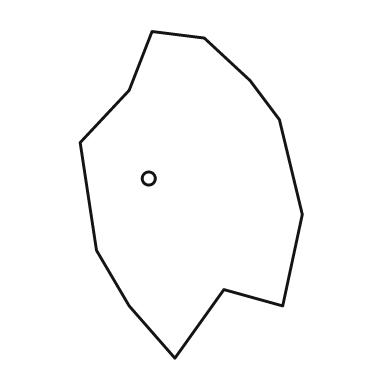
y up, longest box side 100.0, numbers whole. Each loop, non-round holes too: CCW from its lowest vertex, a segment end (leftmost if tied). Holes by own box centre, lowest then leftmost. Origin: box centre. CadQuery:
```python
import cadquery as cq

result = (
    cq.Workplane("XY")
    .moveTo(-5.0, -50.0)
    .lineTo(10.0, -29.0)
    .lineTo(28.0, -34.0)
    .lineTo(34.0, -6.0)
    .lineTo(27.0, 23.0)
    .lineTo(18.0, 35.0)
    .lineTo(4.0, 48.0)
    .lineTo(-12.0, 50.0)
    .lineTo(-19.0, 32.0)
    .lineTo(-34.0, 16.0)
    .lineTo(-29.0, -17.0)
    .lineTo(-19.0, -34.0)
    .close()
    .moveTo(-13.0, 5.0)
    .circle(2.0)
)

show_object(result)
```